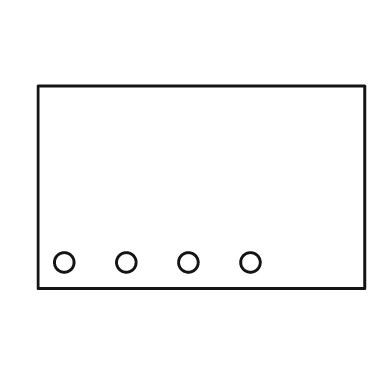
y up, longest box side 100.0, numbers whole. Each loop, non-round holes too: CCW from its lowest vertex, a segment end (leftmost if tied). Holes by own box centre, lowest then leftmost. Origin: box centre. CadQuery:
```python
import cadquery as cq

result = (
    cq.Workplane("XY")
    .moveTo(-50.0, -31.0)
    .lineTo(50.0, -31.0)
    .lineTo(50.0, 31.0)
    .lineTo(-50.0, 31.0)
    .close()
    .moveTo(-42.0, -23.0)
    .circle(3.0)
    .moveTo(-23.0, -23.0)
    .circle(3.0)
    .moveTo(-4.0, -23.0)
    .circle(3.0)
    .moveTo(15.0, -23.0)
    .circle(3.0)
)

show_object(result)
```